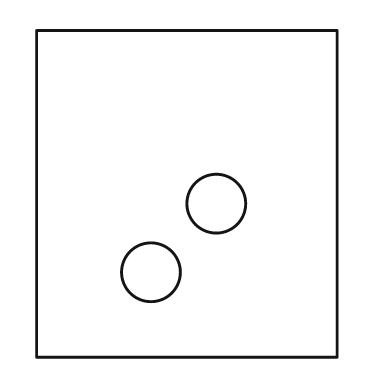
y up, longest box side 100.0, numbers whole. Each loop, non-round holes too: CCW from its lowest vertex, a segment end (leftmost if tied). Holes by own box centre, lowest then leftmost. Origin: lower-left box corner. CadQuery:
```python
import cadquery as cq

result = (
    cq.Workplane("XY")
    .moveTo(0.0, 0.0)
    .lineTo(92.0, 0.0)
    .lineTo(92.0, 100.0)
    .lineTo(0.0, 100.0)
    .close()
    .moveTo(35.0, 26.0)
    .circle(9.0)
    .moveTo(55.0, 47.0)
    .circle(9.0)
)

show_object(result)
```